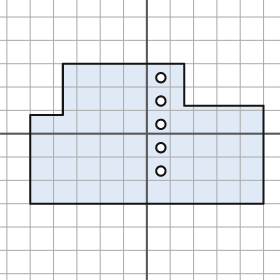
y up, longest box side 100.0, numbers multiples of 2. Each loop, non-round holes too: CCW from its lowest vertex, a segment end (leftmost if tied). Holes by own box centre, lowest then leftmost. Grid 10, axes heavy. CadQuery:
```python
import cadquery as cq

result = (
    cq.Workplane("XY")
    .moveTo(-50.0, -30.0)
    .lineTo(50.0, -30.0)
    .lineTo(50.0, 12.0)
    .lineTo(16.0, 12.0)
    .lineTo(16.0, 30.0)
    .lineTo(-36.0, 30.0)
    .lineTo(-36.0, 8.0)
    .lineTo(-50.0, 8.0)
    .close()
    .moveTo(6.0, -16.0)
    .circle(2.0)
    .moveTo(6.0, -6.0)
    .circle(2.0)
    .moveTo(6.0, 4.0)
    .circle(2.0)
    .moveTo(6.0, 14.0)
    .circle(2.0)
    .moveTo(6.0, 24.0)
    .circle(2.0)
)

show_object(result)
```